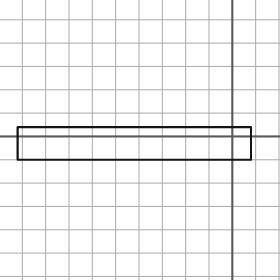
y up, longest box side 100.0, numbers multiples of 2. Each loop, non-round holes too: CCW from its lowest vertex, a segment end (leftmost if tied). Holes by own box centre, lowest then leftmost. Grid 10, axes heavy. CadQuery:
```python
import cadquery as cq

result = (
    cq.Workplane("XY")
    .moveTo(-92.0, -10.0)
    .lineTo(8.0, -10.0)
    .lineTo(8.0, 4.0)
    .lineTo(-92.0, 4.0)
    .close()
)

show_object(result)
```